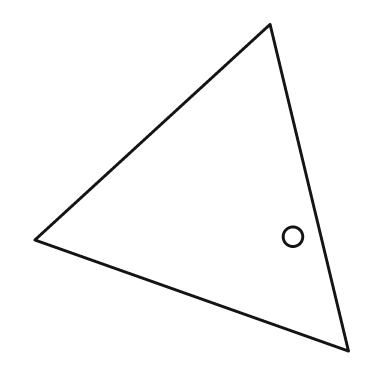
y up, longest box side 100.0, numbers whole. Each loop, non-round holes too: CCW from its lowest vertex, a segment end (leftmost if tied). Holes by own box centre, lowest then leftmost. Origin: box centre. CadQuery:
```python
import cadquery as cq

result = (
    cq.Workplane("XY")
    .moveTo(48.0, -50.0)
    .lineTo(24.0, 50.0)
    .lineTo(-48.0, -16.0)
    .close()
    .moveTo(31.0, -15.0)
    .circle(3.0)
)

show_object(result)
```